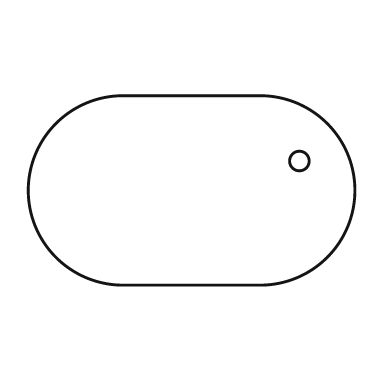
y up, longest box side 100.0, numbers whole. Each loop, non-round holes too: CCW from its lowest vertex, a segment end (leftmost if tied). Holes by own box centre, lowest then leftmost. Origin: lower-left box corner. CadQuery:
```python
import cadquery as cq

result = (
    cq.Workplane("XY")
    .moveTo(29.0, 0.0)
    .lineTo(71.0, 0.0)
    .threePointArc((100.0, 29.0), (71.0, 58.0))
    .lineTo(29.0, 58.0)
    .threePointArc((0.0, 29.0), (29.0, 0.0))
    .close()
    .moveTo(83.0, 38.0)
    .circle(3.0)
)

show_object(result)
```